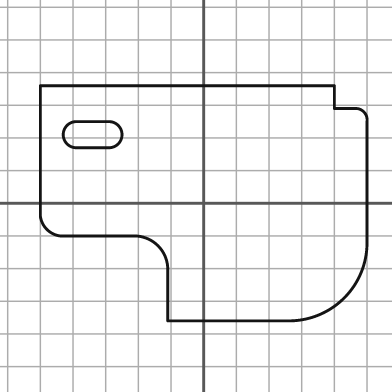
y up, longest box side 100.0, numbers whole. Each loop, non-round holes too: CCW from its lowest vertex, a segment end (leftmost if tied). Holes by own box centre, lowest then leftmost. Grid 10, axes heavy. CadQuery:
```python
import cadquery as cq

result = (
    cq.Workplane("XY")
    .moveTo(-11.0, -36.0)
    .lineTo(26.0, -36.0)
    .threePointArc((43.0, -29.0), (50.0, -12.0))
    .lineTo(50.0, 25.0)
    .threePointArc((49.0, 28.0), (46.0, 29.0))
    .lineTo(40.0, 29.0)
    .lineTo(40.0, 36.0)
    .lineTo(-50.0, 36.0)
    .lineTo(-50.0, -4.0)
    .threePointArc((-48.0, -8.0), (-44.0, -10.0))
    .lineTo(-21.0, -10.0)
    .threePointArc((-14.0, -13.0), (-11.0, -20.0))
    .close()
    .moveTo(-39.0, 17.0)
    .lineTo(-29.0, 17.0)
    .threePointArc((-25.0, 21.0), (-29.0, 25.0))
    .lineTo(-39.0, 25.0)
    .threePointArc((-43.0, 21.0), (-39.0, 17.0))
    .close()
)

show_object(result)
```